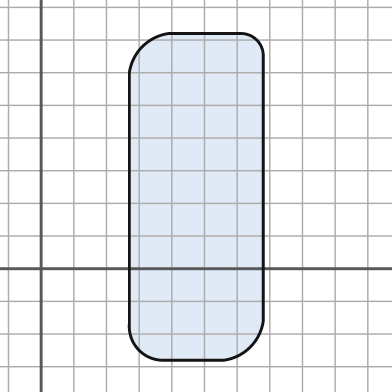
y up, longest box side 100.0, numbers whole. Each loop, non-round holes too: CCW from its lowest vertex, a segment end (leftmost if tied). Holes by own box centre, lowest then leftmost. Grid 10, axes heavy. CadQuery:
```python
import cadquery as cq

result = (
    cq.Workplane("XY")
    .moveTo(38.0, -28.0)
    .lineTo(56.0, -28.0)
    .threePointArc((64.0, -24.0), (68.0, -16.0))
    .lineTo(68.0, 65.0)
    .threePointArc((66.0, 70.0), (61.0, 72.0))
    .lineTo(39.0, 72.0)
    .threePointArc((31.0, 68.0), (27.0, 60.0))
    .lineTo(27.0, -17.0)
    .threePointArc((30.0, -25.0), (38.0, -28.0))
    .close()
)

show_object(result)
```